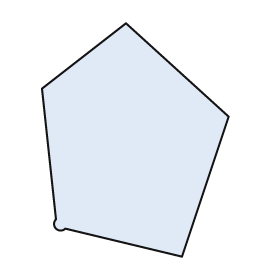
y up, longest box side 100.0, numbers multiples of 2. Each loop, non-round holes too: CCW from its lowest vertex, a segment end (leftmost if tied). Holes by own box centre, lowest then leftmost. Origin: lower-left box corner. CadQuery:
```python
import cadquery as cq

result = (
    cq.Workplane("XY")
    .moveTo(60.0, 0.0)
    .lineTo(80.0, 60.0)
    .lineTo(36.0, 100.0)
    .lineTo(0.0, 72.0)
    .lineTo(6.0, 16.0)
    .threePointArc((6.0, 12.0), (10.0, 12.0))
    .close()
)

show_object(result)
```